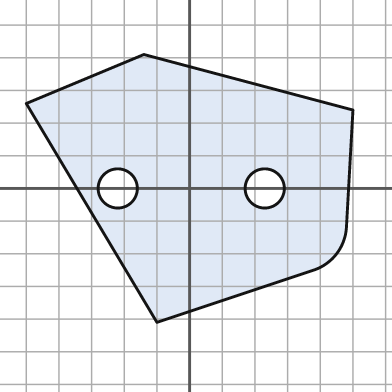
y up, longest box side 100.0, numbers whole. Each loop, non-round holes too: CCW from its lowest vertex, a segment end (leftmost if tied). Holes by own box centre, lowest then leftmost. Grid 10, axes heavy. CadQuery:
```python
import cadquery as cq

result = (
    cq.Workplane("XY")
    .moveTo(-10.0, -41.0)
    .lineTo(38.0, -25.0)
    .threePointArc((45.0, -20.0), (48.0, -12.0))
    .lineTo(50.0, 24.0)
    .lineTo(-14.0, 41.0)
    .lineTo(-50.0, 26.0)
    .close()
    .moveTo(-22.0, 0.0)
    .circle(6.0)
    .moveTo(23.0, 0.0)
    .circle(6.0)
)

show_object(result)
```